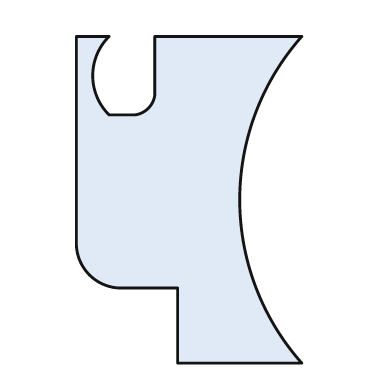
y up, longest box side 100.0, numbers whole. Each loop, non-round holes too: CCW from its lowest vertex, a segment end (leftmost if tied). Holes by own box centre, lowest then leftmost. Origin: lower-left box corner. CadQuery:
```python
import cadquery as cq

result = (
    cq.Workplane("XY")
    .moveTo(31.0, 0.0)
    .lineTo(69.0, 0.0)
    .threePointArc((50.0, 50.0), (69.0, 100.0))
    .lineTo(24.0, 100.0)
    .lineTo(24.0, 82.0)
    .threePointArc((22.0, 78.0), (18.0, 76.0))
    .lineTo(10.0, 76.0)
    .threePointArc((5.0, 88.0), (10.0, 100.0))
    .lineTo(0.0, 100.0)
    .lineTo(0.0, 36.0)
    .threePointArc((4.0, 27.0), (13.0, 23.0))
    .lineTo(31.0, 23.0)
    .close()
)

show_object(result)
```